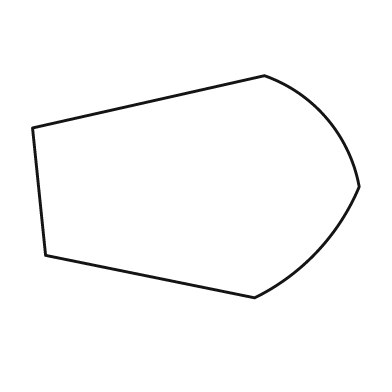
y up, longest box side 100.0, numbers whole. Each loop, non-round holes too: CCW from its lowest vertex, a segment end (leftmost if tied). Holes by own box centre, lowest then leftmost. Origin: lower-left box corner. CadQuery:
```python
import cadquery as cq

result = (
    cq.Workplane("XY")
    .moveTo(68.0, 0.0)
    .threePointArc((87.0, 14.0), (100.0, 34.0))
    .threePointArc((90.0, 55.0), (71.0, 68.0))
    .lineTo(0.0, 52.0)
    .lineTo(4.0, 13.0)
    .close()
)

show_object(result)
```